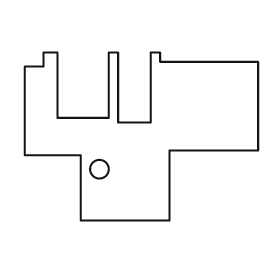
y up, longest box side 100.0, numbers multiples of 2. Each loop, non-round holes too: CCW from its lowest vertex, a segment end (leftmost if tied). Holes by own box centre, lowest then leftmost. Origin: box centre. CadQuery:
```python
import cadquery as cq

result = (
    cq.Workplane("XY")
    .moveTo(-26.0, -36.0)
    .lineTo(12.0, -36.0)
    .lineTo(12.0, -6.0)
    .lineTo(50.0, -6.0)
    .lineTo(50.0, 32.0)
    .lineTo(8.0, 32.0)
    .lineTo(8.0, 36.0)
    .lineTo(4.0, 36.0)
    .lineTo(4.0, 6.0)
    .lineTo(-10.0, 6.0)
    .lineTo(-10.0, 36.0)
    .lineTo(-14.0, 36.0)
    .lineTo(-14.0, 8.0)
    .lineTo(-36.0, 8.0)
    .lineTo(-36.0, 36.0)
    .lineTo(-42.0, 36.0)
    .lineTo(-42.0, 30.0)
    .lineTo(-50.0, 30.0)
    .lineTo(-50.0, -8.0)
    .lineTo(-26.0, -8.0)
    .close()
    .moveTo(-18.0, -14.0)
    .circle(4.0)
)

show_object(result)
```